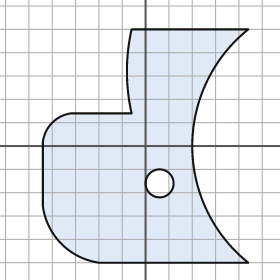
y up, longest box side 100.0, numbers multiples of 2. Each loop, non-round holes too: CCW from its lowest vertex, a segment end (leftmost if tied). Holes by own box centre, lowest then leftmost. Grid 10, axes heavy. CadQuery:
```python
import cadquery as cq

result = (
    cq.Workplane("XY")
    .moveTo(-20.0, -50.0)
    .lineTo(44.0, -50.0)
    .threePointArc((20.0, 0.0), (44.0, 50.0))
    .lineTo(-6.0, 50.0)
    .threePointArc((-8.0, 32.0), (-6.0, 14.0))
    .lineTo(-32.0, 14.0)
    .threePointArc((-40.0, 10.0), (-44.0, 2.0))
    .lineTo(-44.0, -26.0)
    .threePointArc((-36.0, -42.0), (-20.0, -50.0))
    .close()
    .moveTo(6.0, -16.0)
    .circle(6.0)
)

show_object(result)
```